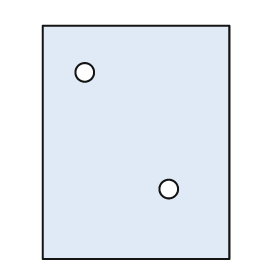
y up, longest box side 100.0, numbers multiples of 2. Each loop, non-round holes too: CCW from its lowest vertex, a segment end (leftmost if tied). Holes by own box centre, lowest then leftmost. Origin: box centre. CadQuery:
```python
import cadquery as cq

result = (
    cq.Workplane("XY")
    .moveTo(-40.0, -50.0)
    .lineTo(40.0, -50.0)
    .lineTo(40.0, 50.0)
    .lineTo(-40.0, 50.0)
    .close()
    .moveTo(14.0, -20.0)
    .circle(4.0)
    .moveTo(-22.0, 30.0)
    .circle(4.0)
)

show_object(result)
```